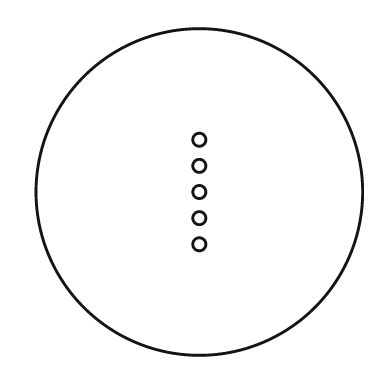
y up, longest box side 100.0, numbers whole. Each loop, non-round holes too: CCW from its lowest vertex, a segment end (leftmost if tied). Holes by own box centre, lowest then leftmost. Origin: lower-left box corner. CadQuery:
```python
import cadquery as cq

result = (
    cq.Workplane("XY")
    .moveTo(50.0, 50.0)
    .circle(50.0)
    .moveTo(50.0, 34.0)
    .circle(2.0)
    .moveTo(50.0, 42.0)
    .circle(2.0)
    .moveTo(50.0, 50.0)
    .circle(2.0)
    .moveTo(50.0, 58.0)
    .circle(2.0)
    .moveTo(50.0, 66.0)
    .circle(2.0)
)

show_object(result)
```